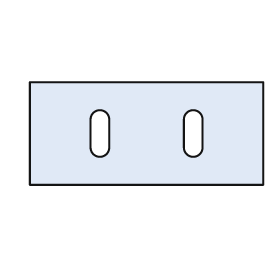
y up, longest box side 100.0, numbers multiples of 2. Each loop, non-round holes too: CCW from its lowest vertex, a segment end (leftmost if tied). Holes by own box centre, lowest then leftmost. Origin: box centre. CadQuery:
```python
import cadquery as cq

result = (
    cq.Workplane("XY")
    .moveTo(-50.0, -22.0)
    .lineTo(50.0, -22.0)
    .lineTo(50.0, 22.0)
    .lineTo(-50.0, 22.0)
    .close()
    .moveTo(-24.0, -6.0)
    .threePointArc((-20.0, -10.0), (-16.0, -6.0))
    .lineTo(-16.0, 6.0)
    .threePointArc((-20.0, 10.0), (-24.0, 6.0))
    .close()
    .moveTo(16.0, -6.0)
    .threePointArc((20.0, -10.0), (24.0, -6.0))
    .lineTo(24.0, 6.0)
    .threePointArc((20.0, 10.0), (16.0, 6.0))
    .close()
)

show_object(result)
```